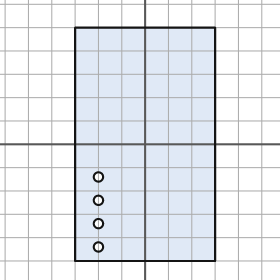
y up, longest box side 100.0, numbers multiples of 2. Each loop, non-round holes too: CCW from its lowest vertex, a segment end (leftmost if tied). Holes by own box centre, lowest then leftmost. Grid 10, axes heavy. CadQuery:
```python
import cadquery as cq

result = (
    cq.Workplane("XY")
    .moveTo(-30.0, -50.0)
    .lineTo(30.0, -50.0)
    .lineTo(30.0, 50.0)
    .lineTo(-30.0, 50.0)
    .close()
    .moveTo(-20.0, -44.0)
    .circle(2.0)
    .moveTo(-20.0, -34.0)
    .circle(2.0)
    .moveTo(-20.0, -24.0)
    .circle(2.0)
    .moveTo(-20.0, -14.0)
    .circle(2.0)
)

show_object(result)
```